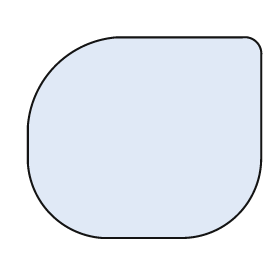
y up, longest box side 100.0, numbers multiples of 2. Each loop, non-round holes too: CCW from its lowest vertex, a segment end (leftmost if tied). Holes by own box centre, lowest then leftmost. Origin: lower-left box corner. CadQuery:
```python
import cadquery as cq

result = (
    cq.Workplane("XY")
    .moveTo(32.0, 0.0)
    .lineTo(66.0, 0.0)
    .threePointArc((90.0, 10.0), (100.0, 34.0))
    .lineTo(100.0, 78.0)
    .threePointArc((98.0, 84.0), (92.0, 86.0))
    .lineTo(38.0, 86.0)
    .threePointArc((12.0, 74.0), (0.0, 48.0))
    .lineTo(0.0, 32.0)
    .threePointArc((10.0, 10.0), (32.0, 0.0))
    .close()
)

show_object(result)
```